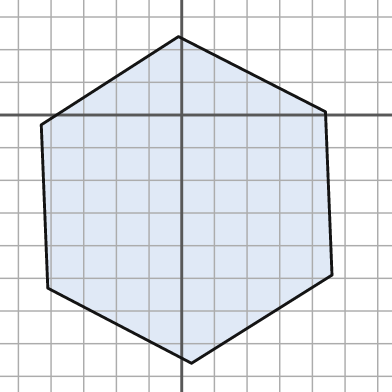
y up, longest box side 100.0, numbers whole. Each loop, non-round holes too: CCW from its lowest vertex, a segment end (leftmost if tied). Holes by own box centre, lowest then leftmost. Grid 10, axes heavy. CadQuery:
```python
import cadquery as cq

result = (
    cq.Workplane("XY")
    .moveTo(3.0, -76.0)
    .lineTo(46.0, -49.0)
    .lineTo(44.0, 1.0)
    .lineTo(-1.0, 24.0)
    .lineTo(-43.0, -3.0)
    .lineTo(-41.0, -53.0)
    .close()
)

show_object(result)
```